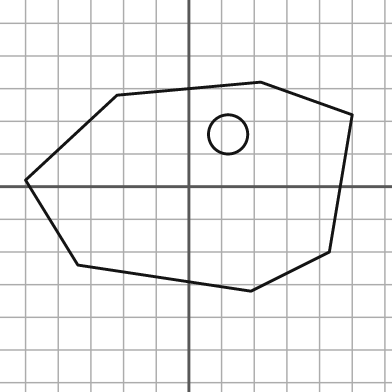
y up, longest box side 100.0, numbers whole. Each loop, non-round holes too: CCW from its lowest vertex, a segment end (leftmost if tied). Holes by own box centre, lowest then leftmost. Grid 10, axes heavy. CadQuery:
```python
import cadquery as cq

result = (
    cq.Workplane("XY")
    .moveTo(19.0, -32.0)
    .lineTo(43.0, -20.0)
    .lineTo(50.0, 22.0)
    .lineTo(22.0, 32.0)
    .lineTo(-22.0, 28.0)
    .lineTo(-50.0, 2.0)
    .lineTo(-34.0, -24.0)
    .close()
    .moveTo(12.0, 16.0)
    .circle(6.0)
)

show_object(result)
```